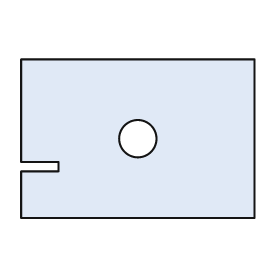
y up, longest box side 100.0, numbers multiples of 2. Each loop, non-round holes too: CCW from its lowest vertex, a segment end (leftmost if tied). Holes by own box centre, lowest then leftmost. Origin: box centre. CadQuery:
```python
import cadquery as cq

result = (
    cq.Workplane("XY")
    .moveTo(-50.0, -34.0)
    .lineTo(50.0, -34.0)
    .lineTo(50.0, 34.0)
    .lineTo(-50.0, 34.0)
    .lineTo(-50.0, -10.0)
    .lineTo(-34.0, -10.0)
    .lineTo(-34.0, -14.0)
    .lineTo(-50.0, -14.0)
    .close()
    .moveTo(0.0, 0.0)
    .circle(8.0)
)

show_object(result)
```